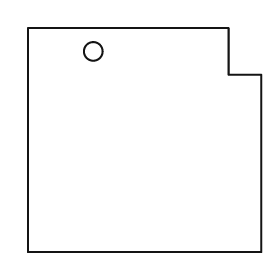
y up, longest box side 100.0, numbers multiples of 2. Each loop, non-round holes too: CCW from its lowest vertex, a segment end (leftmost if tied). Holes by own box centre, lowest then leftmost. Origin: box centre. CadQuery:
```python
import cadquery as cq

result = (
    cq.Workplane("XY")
    .moveTo(-50.0, -48.0)
    .lineTo(50.0, -48.0)
    .lineTo(50.0, 28.0)
    .lineTo(36.0, 28.0)
    .lineTo(36.0, 48.0)
    .lineTo(-50.0, 48.0)
    .close()
    .moveTo(-22.0, 38.0)
    .circle(4.0)
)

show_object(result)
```